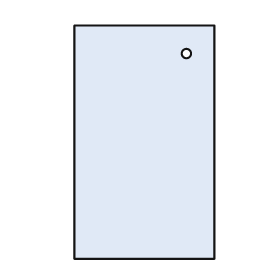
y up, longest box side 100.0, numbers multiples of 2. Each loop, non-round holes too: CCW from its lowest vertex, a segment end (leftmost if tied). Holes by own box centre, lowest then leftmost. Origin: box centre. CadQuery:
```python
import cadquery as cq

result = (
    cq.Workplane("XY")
    .moveTo(-30.0, -50.0)
    .lineTo(30.0, -50.0)
    .lineTo(30.0, 50.0)
    .lineTo(-30.0, 50.0)
    .close()
    .moveTo(18.0, 38.0)
    .circle(2.0)
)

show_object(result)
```